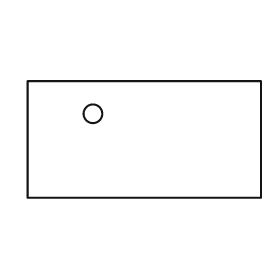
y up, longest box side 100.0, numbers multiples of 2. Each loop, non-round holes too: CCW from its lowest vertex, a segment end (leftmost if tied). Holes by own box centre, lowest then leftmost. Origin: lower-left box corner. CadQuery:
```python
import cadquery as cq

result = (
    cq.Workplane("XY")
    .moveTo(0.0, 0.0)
    .lineTo(100.0, 0.0)
    .lineTo(100.0, 50.0)
    .lineTo(0.0, 50.0)
    .close()
    .moveTo(28.0, 36.0)
    .circle(4.0)
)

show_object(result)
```